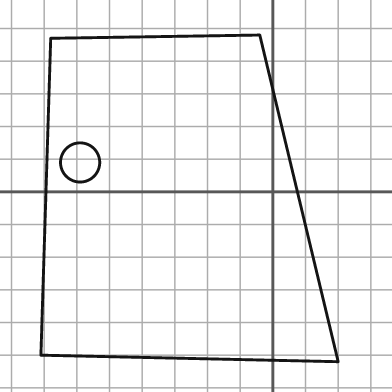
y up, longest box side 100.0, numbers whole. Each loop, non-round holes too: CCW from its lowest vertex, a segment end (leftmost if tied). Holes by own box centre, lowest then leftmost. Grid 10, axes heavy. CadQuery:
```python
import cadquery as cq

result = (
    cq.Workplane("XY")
    .moveTo(20.0, -52.0)
    .lineTo(-4.0, 48.0)
    .lineTo(-68.0, 47.0)
    .lineTo(-71.0, -50.0)
    .close()
    .moveTo(-59.0, 9.0)
    .circle(6.0)
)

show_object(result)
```